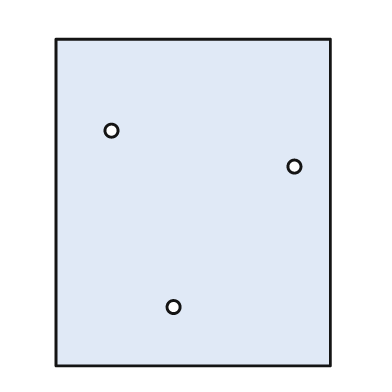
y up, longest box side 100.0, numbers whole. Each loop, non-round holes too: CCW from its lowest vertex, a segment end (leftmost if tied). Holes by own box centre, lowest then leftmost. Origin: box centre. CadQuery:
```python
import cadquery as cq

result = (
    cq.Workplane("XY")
    .moveTo(-42.0, -50.0)
    .lineTo(42.0, -50.0)
    .lineTo(42.0, 50.0)
    .lineTo(-42.0, 50.0)
    .close()
    .moveTo(-6.0, -32.0)
    .circle(2.0)
    .moveTo(31.0, 11.0)
    .circle(2.0)
    .moveTo(-25.0, 22.0)
    .circle(2.0)
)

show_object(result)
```